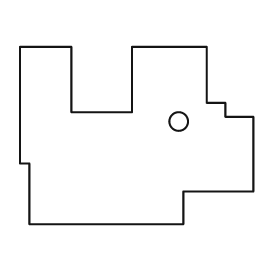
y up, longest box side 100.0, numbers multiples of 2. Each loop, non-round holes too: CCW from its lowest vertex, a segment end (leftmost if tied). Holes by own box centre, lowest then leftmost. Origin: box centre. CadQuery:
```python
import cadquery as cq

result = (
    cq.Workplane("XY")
    .moveTo(-46.0, -38.0)
    .lineTo(20.0, -38.0)
    .lineTo(20.0, -24.0)
    .lineTo(50.0, -24.0)
    .lineTo(50.0, 8.0)
    .lineTo(38.0, 8.0)
    .lineTo(38.0, 14.0)
    .lineTo(30.0, 14.0)
    .lineTo(30.0, 38.0)
    .lineTo(-2.0, 38.0)
    .lineTo(-2.0, 10.0)
    .lineTo(-28.0, 10.0)
    .lineTo(-28.0, 38.0)
    .lineTo(-50.0, 38.0)
    .lineTo(-50.0, -12.0)
    .lineTo(-46.0, -12.0)
    .close()
    .moveTo(18.0, 6.0)
    .circle(4.0)
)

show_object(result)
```